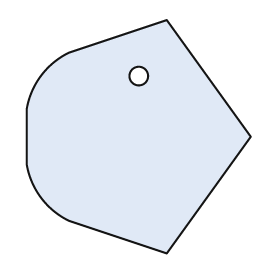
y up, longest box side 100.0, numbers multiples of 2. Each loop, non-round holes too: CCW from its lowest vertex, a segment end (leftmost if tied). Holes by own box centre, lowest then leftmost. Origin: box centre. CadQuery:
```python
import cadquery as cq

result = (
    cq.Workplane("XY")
    .moveTo(12.0, -50.0)
    .lineTo(48.0, 0.0)
    .lineTo(12.0, 50.0)
    .lineTo(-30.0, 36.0)
    .threePointArc((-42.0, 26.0), (-48.0, 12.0))
    .lineTo(-48.0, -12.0)
    .threePointArc((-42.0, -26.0), (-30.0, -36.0))
    .close()
    .moveTo(0.0, 26.0)
    .circle(4.0)
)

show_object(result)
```